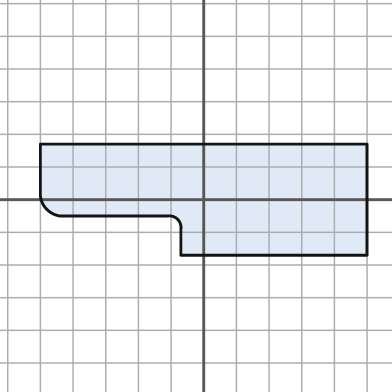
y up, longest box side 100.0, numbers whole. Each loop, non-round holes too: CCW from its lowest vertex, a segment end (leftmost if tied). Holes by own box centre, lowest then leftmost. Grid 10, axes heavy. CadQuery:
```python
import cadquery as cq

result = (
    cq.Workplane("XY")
    .moveTo(-7.0, -17.0)
    .lineTo(50.0, -17.0)
    .lineTo(50.0, 17.0)
    .lineTo(-50.0, 17.0)
    .lineTo(-50.0, 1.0)
    .threePointArc((-48.0, -3.0), (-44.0, -5.0))
    .lineTo(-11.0, -5.0)
    .threePointArc((-8.0, -6.0), (-7.0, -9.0))
    .close()
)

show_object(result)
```